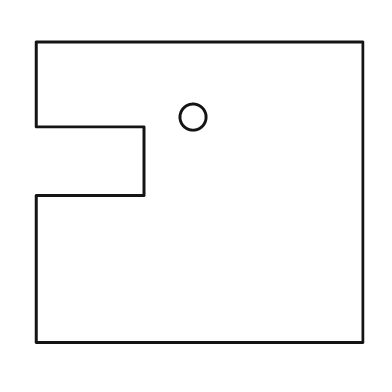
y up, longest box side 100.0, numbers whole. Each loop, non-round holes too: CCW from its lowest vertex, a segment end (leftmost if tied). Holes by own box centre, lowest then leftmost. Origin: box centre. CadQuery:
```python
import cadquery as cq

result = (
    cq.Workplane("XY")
    .moveTo(-50.0, -46.0)
    .lineTo(50.0, -46.0)
    .lineTo(50.0, 46.0)
    .lineTo(-50.0, 46.0)
    .lineTo(-50.0, 20.0)
    .lineTo(-17.0, 20.0)
    .lineTo(-17.0, -1.0)
    .lineTo(-50.0, -1.0)
    .close()
    .moveTo(-2.0, 23.0)
    .circle(4.0)
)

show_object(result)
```